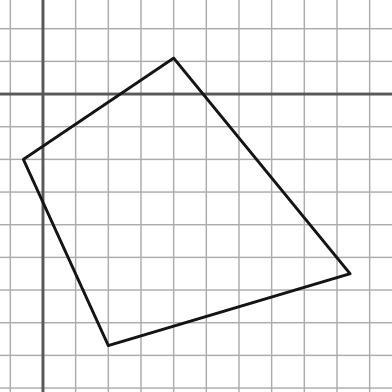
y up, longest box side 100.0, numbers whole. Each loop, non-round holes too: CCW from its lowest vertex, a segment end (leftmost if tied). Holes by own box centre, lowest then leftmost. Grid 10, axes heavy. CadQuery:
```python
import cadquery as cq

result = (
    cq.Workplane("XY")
    .moveTo(20.0, -77.0)
    .lineTo(94.0, -55.0)
    .lineTo(40.0, 11.0)
    .lineTo(-6.0, -20.0)
    .close()
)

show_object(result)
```